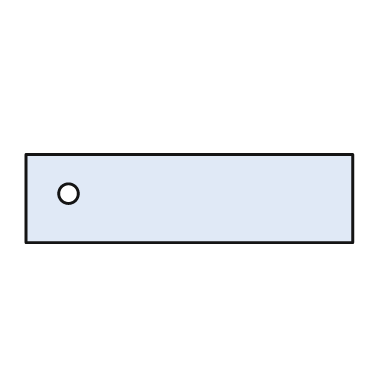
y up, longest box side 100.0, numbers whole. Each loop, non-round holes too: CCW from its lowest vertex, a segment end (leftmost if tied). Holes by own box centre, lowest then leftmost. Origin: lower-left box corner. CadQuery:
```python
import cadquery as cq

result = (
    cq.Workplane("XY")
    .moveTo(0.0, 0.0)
    .lineTo(100.0, 0.0)
    .lineTo(100.0, 27.0)
    .lineTo(0.0, 27.0)
    .close()
    .moveTo(13.0, 15.0)
    .circle(3.0)
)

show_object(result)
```